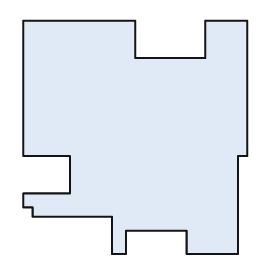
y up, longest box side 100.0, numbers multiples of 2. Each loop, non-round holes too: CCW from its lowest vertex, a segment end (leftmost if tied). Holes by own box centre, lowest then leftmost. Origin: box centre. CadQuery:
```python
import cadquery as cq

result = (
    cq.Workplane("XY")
    .moveTo(-10.0, -50.0)
    .lineTo(-4.0, -50.0)
    .lineTo(-4.0, -40.0)
    .lineTo(22.0, -40.0)
    .lineTo(22.0, -50.0)
    .lineTo(44.0, -50.0)
    .lineTo(44.0, -8.0)
    .lineTo(48.0, -8.0)
    .lineTo(48.0, 50.0)
    .lineTo(30.0, 50.0)
    .lineTo(30.0, 34.0)
    .lineTo(0.0, 34.0)
    .lineTo(0.0, 50.0)
    .lineTo(-48.0, 50.0)
    .lineTo(-48.0, -8.0)
    .lineTo(-28.0, -8.0)
    .lineTo(-28.0, -24.0)
    .lineTo(-48.0, -24.0)
    .lineTo(-48.0, -30.0)
    .lineTo(-44.0, -30.0)
    .lineTo(-44.0, -34.0)
    .lineTo(-10.0, -34.0)
    .close()
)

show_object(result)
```